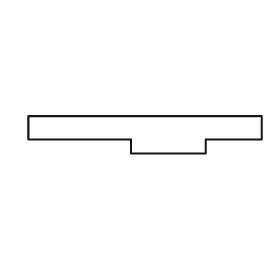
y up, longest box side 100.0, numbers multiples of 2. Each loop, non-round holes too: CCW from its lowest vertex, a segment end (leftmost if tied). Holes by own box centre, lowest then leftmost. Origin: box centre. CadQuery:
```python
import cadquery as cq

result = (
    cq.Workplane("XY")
    .moveTo(-6.0, -8.0)
    .lineTo(26.0, -8.0)
    .lineTo(26.0, -2.0)
    .lineTo(50.0, -2.0)
    .lineTo(50.0, 8.0)
    .lineTo(-50.0, 8.0)
    .lineTo(-50.0, -2.0)
    .lineTo(-6.0, -2.0)
    .close()
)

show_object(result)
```